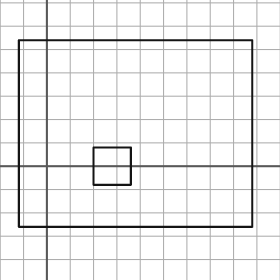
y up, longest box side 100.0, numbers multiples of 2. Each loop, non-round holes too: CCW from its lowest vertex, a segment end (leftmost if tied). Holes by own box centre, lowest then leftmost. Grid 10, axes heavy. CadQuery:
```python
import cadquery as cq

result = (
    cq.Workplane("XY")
    .moveTo(-12.0, -26.0)
    .lineTo(88.0, -26.0)
    .lineTo(88.0, 54.0)
    .lineTo(-12.0, 54.0)
    .close()
    .moveTo(20.0, -8.0)
    .lineTo(36.0, -8.0)
    .lineTo(36.0, 8.0)
    .lineTo(20.0, 8.0)
    .close()
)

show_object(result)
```